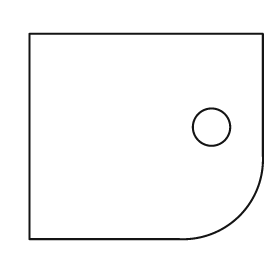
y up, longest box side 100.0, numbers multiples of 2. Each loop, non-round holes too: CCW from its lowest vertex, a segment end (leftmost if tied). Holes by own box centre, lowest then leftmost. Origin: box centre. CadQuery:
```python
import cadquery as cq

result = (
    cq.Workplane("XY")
    .moveTo(-50.0, -44.0)
    .lineTo(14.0, -44.0)
    .threePointArc((40.0, -34.0), (50.0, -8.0))
    .lineTo(50.0, 44.0)
    .lineTo(-50.0, 44.0)
    .close()
    .moveTo(28.0, 4.0)
    .circle(8.0)
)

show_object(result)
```